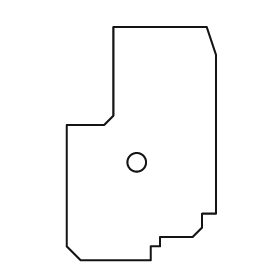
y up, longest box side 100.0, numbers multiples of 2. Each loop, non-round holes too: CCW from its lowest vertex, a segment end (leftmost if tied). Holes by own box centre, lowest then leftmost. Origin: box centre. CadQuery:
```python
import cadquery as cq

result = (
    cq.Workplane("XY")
    .moveTo(-26.0, -50.0)
    .lineTo(4.0, -50.0)
    .lineTo(4.0, -44.0)
    .lineTo(8.0, -44.0)
    .lineTo(8.0, -40.0)
    .lineTo(22.0, -40.0)
    .lineTo(26.0, -36.0)
    .lineTo(26.0, -30.0)
    .lineTo(32.0, -30.0)
    .lineTo(32.0, 38.0)
    .lineTo(28.0, 50.0)
    .lineTo(-12.0, 50.0)
    .lineTo(-12.0, 12.0)
    .lineTo(-16.0, 8.0)
    .lineTo(-32.0, 8.0)
    .lineTo(-32.0, -44.0)
    .close()
    .moveTo(-2.0, -8.0)
    .circle(4.0)
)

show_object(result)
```